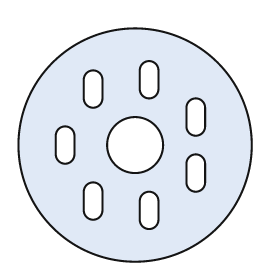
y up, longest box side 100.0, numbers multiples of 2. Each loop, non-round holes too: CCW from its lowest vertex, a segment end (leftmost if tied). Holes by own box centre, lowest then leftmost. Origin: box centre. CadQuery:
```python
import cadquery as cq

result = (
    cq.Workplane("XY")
    .moveTo(0.0, 0.0)
    .circle(50.0)
    .moveTo(2.0, -32.0)
    .threePointArc((6.0, -36.0), (10.0, -32.0))
    .lineTo(10.0, -24.0)
    .threePointArc((6.0, -20.0), (2.0, -24.0))
    .close()
    .moveTo(-22.0, -28.0)
    .threePointArc((-18.0, -32.0), (-14.0, -28.0))
    .lineTo(-14.0, -20.0)
    .threePointArc((-18.0, -16.0), (-22.0, -20.0))
    .close()
    .moveTo(22.0, -16.0)
    .threePointArc((26.0, -20.0), (30.0, -16.0))
    .lineTo(30.0, -8.0)
    .threePointArc((26.0, -4.0), (22.0, -8.0))
    .close()
    .moveTo(-34.0, -4.0)
    .threePointArc((-30.0, -8.0), (-26.0, -4.0))
    .lineTo(-26.0, 4.0)
    .threePointArc((-30.0, 8.0), (-34.0, 4.0))
    .close()
    .moveTo(0.0, 0.0)
    .circle(12.0)
    .moveTo(22.0, 8.0)
    .threePointArc((26.0, 4.0), (30.0, 8.0))
    .lineTo(30.0, 16.0)
    .threePointArc((26.0, 20.0), (22.0, 16.0))
    .close()
    .moveTo(-22.0, 20.0)
    .threePointArc((-18.0, 16.0), (-14.0, 20.0))
    .lineTo(-14.0, 28.0)
    .threePointArc((-18.0, 32.0), (-22.0, 28.0))
    .close()
    .moveTo(2.0, 24.0)
    .threePointArc((6.0, 20.0), (10.0, 24.0))
    .lineTo(10.0, 32.0)
    .threePointArc((6.0, 36.0), (2.0, 32.0))
    .close()
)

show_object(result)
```